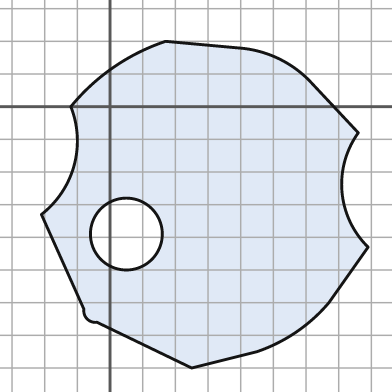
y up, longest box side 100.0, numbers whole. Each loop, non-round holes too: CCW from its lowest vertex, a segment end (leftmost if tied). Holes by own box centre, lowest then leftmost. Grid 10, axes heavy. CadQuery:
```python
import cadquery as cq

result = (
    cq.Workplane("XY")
    .moveTo(25.0, -80.0)
    .lineTo(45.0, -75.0)
    .threePointArc((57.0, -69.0), (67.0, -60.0))
    .lineTo(79.0, -43.0)
    .threePointArc((71.0, -26.0), (76.0, -8.0))
    .lineTo(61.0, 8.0)
    .threePointArc((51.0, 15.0), (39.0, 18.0))
    .lineTo(17.0, 20.0)
    .threePointArc((1.0, 12.0), (-12.0, 0.0))
    .threePointArc((-11.0, -18.0), (-21.0, -33.0))
    .lineTo(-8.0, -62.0)
    .threePointArc((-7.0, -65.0), (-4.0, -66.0))
    .close()
    .moveTo(5.0, -39.0)
    .circle(11.0)
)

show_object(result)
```